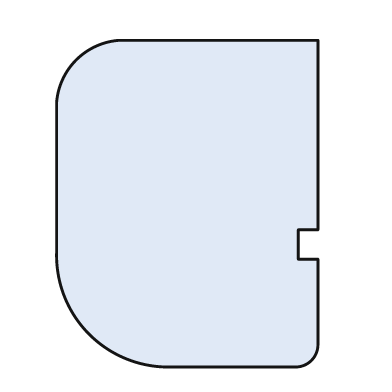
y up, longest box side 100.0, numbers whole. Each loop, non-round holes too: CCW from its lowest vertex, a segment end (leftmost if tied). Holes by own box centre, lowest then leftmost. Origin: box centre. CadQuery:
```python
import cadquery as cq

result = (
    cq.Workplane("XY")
    .moveTo(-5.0, -50.0)
    .lineTo(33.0, -50.0)
    .threePointArc((38.0, -48.0), (40.0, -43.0))
    .lineTo(40.0, -17.0)
    .lineTo(34.0, -17.0)
    .lineTo(34.0, -8.0)
    .lineTo(40.0, -8.0)
    .lineTo(40.0, 50.0)
    .lineTo(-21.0, 50.0)
    .threePointArc((-34.0, 44.0), (-40.0, 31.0))
    .lineTo(-40.0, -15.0)
    .threePointArc((-30.0, -40.0), (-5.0, -50.0))
    .close()
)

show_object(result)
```